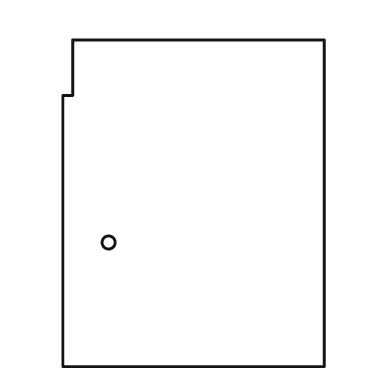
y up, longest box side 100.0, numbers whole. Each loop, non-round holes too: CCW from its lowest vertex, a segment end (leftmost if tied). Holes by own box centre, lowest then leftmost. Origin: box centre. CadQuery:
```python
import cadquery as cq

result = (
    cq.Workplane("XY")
    .moveTo(-40.0, -50.0)
    .lineTo(40.0, -50.0)
    .lineTo(40.0, 50.0)
    .lineTo(-37.0, 50.0)
    .lineTo(-37.0, 33.0)
    .lineTo(-40.0, 33.0)
    .close()
    .moveTo(-26.0, -12.0)
    .circle(2.0)
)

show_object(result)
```